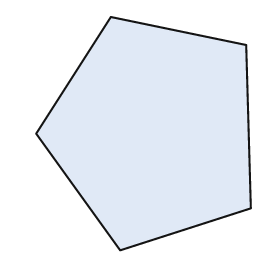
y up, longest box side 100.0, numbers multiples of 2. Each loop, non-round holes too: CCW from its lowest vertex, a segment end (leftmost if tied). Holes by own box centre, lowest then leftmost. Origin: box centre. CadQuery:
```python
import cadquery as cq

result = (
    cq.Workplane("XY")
    .moveTo(-10.0, -50.0)
    .lineTo(46.0, -32.0)
    .lineTo(44.0, 38.0)
    .lineTo(-14.0, 50.0)
    .lineTo(-46.0, 0.0)
    .close()
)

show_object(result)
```